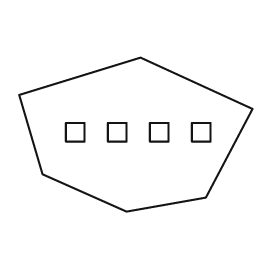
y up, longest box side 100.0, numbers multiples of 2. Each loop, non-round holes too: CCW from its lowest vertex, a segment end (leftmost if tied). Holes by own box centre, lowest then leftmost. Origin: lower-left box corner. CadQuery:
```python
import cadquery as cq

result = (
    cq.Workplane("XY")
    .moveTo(46.0, 0.0)
    .lineTo(80.0, 6.0)
    .lineTo(100.0, 44.0)
    .lineTo(52.0, 66.0)
    .lineTo(0.0, 50.0)
    .lineTo(10.0, 16.0)
    .close()
    .moveTo(20.0, 30.0)
    .lineTo(28.0, 30.0)
    .lineTo(28.0, 38.0)
    .lineTo(20.0, 38.0)
    .close()
    .moveTo(38.0, 30.0)
    .lineTo(46.0, 30.0)
    .lineTo(46.0, 38.0)
    .lineTo(38.0, 38.0)
    .close()
    .moveTo(56.0, 30.0)
    .lineTo(64.0, 30.0)
    .lineTo(64.0, 38.0)
    .lineTo(56.0, 38.0)
    .close()
    .moveTo(74.0, 30.0)
    .lineTo(82.0, 30.0)
    .lineTo(82.0, 38.0)
    .lineTo(74.0, 38.0)
    .close()
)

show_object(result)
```